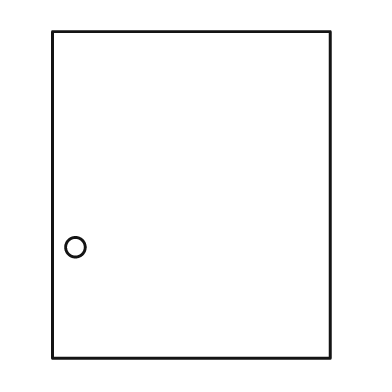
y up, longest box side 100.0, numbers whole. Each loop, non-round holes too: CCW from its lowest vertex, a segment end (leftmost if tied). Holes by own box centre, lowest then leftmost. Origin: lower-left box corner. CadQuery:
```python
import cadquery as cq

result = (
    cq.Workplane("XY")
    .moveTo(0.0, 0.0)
    .lineTo(85.0, 0.0)
    .lineTo(85.0, 100.0)
    .lineTo(0.0, 100.0)
    .close()
    .moveTo(7.0, 34.0)
    .circle(3.0)
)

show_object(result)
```